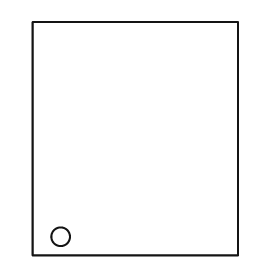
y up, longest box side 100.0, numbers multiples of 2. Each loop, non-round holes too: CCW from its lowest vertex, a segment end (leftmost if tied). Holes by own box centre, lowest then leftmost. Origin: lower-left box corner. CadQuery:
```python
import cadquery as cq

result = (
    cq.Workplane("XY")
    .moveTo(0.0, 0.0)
    .lineTo(88.0, 0.0)
    .lineTo(88.0, 100.0)
    .lineTo(0.0, 100.0)
    .close()
    .moveTo(12.0, 8.0)
    .circle(4.0)
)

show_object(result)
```